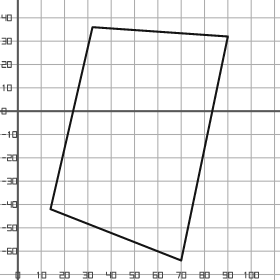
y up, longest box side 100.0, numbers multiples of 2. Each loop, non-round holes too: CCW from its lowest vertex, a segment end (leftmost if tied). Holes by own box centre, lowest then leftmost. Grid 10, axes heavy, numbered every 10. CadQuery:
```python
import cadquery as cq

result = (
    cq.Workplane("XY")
    .moveTo(70.0, -64.0)
    .lineTo(90.0, 32.0)
    .lineTo(32.0, 36.0)
    .lineTo(14.0, -42.0)
    .close()
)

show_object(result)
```